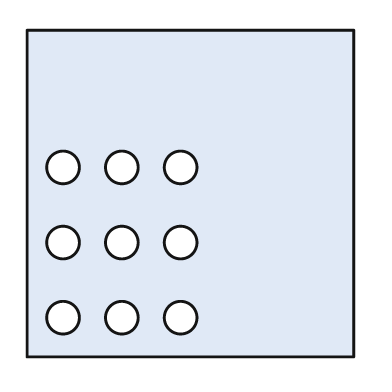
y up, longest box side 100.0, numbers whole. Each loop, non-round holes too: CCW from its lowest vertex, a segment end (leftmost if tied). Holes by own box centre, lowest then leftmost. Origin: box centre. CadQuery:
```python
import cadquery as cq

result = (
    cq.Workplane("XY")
    .moveTo(-50.0, -50.0)
    .lineTo(50.0, -50.0)
    .lineTo(50.0, 50.0)
    .lineTo(-50.0, 50.0)
    .close()
    .moveTo(-39.0, -38.0)
    .circle(5.0)
    .moveTo(-21.0, -38.0)
    .circle(5.0)
    .moveTo(-3.0, -38.0)
    .circle(5.0)
    .moveTo(-39.0, -15.0)
    .circle(5.0)
    .moveTo(-21.0, -15.0)
    .circle(5.0)
    .moveTo(-3.0, -15.0)
    .circle(5.0)
    .moveTo(-39.0, 8.0)
    .circle(5.0)
    .moveTo(-21.0, 8.0)
    .circle(5.0)
    .moveTo(-3.0, 8.0)
    .circle(5.0)
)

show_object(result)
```